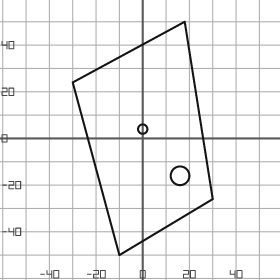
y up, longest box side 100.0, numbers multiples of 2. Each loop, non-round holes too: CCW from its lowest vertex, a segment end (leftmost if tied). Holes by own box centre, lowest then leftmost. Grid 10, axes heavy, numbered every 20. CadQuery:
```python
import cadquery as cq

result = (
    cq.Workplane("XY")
    .moveTo(-10.0, -50.0)
    .lineTo(30.0, -26.0)
    .lineTo(18.0, 50.0)
    .lineTo(-30.0, 24.0)
    .close()
    .moveTo(16.0, -16.0)
    .circle(4.0)
    .moveTo(0.0, 4.0)
    .circle(2.0)
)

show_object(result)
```